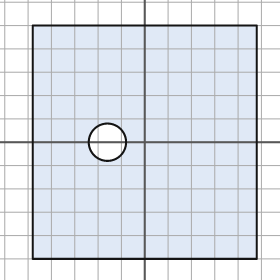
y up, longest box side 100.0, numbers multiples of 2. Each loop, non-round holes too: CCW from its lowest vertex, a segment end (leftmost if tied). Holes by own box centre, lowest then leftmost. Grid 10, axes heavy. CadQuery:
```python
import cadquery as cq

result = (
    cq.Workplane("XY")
    .moveTo(-48.0, -50.0)
    .lineTo(48.0, -50.0)
    .lineTo(48.0, 50.0)
    .lineTo(-48.0, 50.0)
    .close()
    .moveTo(-16.0, 0.0)
    .circle(8.0)
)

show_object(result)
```